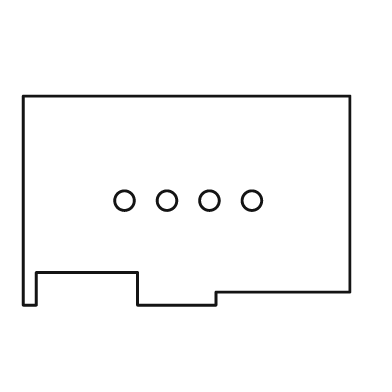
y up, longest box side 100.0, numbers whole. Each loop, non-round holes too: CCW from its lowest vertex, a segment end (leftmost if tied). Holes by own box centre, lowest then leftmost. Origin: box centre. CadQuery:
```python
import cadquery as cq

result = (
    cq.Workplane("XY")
    .moveTo(-50.0, -32.0)
    .lineTo(-46.0, -32.0)
    .lineTo(-46.0, -22.0)
    .lineTo(-15.0, -22.0)
    .lineTo(-15.0, -32.0)
    .lineTo(9.0, -32.0)
    .lineTo(9.0, -28.0)
    .lineTo(50.0, -28.0)
    .lineTo(50.0, 32.0)
    .lineTo(-50.0, 32.0)
    .close()
    .moveTo(-19.0, 0.0)
    .circle(3.0)
    .moveTo(-6.0, 0.0)
    .circle(3.0)
    .moveTo(7.0, 0.0)
    .circle(3.0)
    .moveTo(20.0, 0.0)
    .circle(3.0)
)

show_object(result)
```